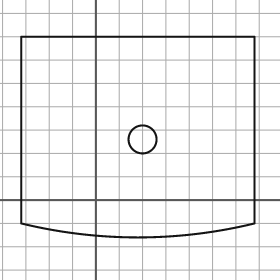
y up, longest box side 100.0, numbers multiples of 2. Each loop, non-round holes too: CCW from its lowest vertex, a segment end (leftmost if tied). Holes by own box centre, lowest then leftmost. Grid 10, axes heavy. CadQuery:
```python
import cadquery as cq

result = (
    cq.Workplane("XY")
    .moveTo(-32.0, -10.0)
    .threePointArc((18.0, -16.0), (68.0, -10.0))
    .lineTo(68.0, 70.0)
    .lineTo(-32.0, 70.0)
    .close()
    .moveTo(20.0, 26.0)
    .circle(6.0)
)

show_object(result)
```